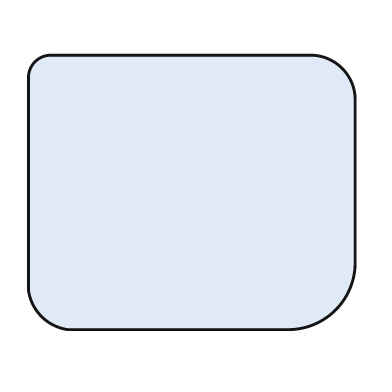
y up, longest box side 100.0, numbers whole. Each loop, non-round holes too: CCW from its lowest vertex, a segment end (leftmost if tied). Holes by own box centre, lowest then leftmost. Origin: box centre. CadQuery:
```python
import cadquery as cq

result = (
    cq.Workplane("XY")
    .moveTo(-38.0, -42.0)
    .lineTo(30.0, -42.0)
    .threePointArc((44.0, -36.0), (50.0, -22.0))
    .lineTo(50.0, 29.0)
    .threePointArc((46.0, 38.0), (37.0, 42.0))
    .lineTo(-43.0, 42.0)
    .threePointArc((-48.0, 40.0), (-50.0, 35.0))
    .lineTo(-50.0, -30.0)
    .threePointArc((-46.0, -38.0), (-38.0, -42.0))
    .close()
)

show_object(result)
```